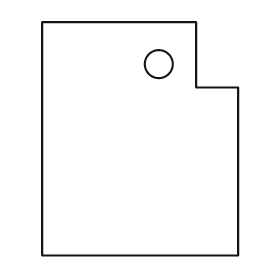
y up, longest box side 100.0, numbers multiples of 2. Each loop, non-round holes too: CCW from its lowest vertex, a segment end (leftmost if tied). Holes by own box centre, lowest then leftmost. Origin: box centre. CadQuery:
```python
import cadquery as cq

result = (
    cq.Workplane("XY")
    .moveTo(-42.0, -50.0)
    .lineTo(42.0, -50.0)
    .lineTo(42.0, 22.0)
    .lineTo(24.0, 22.0)
    .lineTo(24.0, 50.0)
    .lineTo(-42.0, 50.0)
    .close()
    .moveTo(8.0, 32.0)
    .circle(6.0)
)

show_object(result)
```